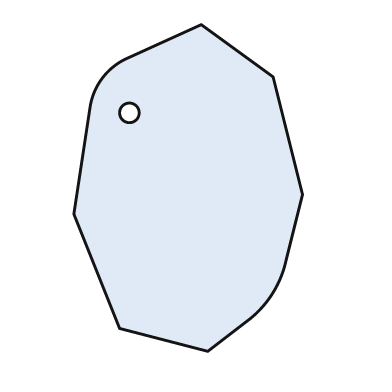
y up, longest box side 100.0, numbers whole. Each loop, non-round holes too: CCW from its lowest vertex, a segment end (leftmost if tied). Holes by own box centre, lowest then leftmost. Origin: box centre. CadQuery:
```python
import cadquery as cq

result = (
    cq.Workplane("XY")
    .moveTo(6.0, -50.0)
    .lineTo(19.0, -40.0)
    .threePointArc((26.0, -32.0), (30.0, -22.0))
    .lineTo(35.0, -2.0)
    .lineTo(26.0, 34.0)
    .lineTo(4.0, 50.0)
    .lineTo(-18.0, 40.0)
    .threePointArc((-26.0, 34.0), (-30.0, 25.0))
    .lineTo(-35.0, -8.0)
    .lineTo(-21.0, -43.0)
    .close()
    .moveTo(-18.0, 23.0)
    .circle(3.0)
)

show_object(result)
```